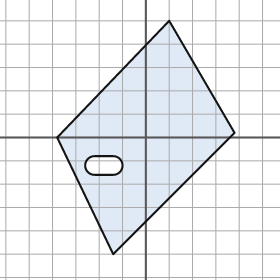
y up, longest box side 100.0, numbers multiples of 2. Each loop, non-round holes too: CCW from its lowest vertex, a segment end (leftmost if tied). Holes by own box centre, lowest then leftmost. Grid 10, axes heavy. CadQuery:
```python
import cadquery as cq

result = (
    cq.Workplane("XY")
    .moveTo(-14.0, -50.0)
    .lineTo(38.0, 2.0)
    .lineTo(10.0, 50.0)
    .lineTo(-38.0, 0.0)
    .close()
    .moveTo(-22.0, -16.0)
    .lineTo(-14.0, -16.0)
    .threePointArc((-10.0, -12.0), (-14.0, -8.0))
    .lineTo(-22.0, -8.0)
    .threePointArc((-26.0, -12.0), (-22.0, -16.0))
    .close()
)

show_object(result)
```